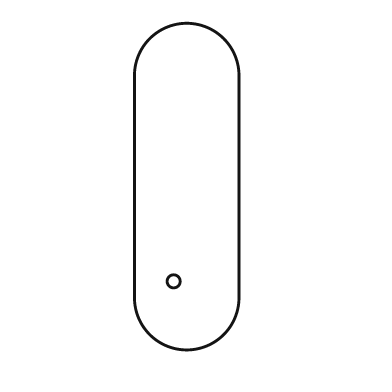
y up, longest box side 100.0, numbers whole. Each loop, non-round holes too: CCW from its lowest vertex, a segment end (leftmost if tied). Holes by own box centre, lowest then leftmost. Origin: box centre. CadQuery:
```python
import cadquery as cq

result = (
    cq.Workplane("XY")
    .moveTo(-16.0, -34.0)
    .threePointArc((0.0, -50.0), (16.0, -34.0))
    .lineTo(16.0, 34.0)
    .threePointArc((0.0, 50.0), (-16.0, 34.0))
    .close()
    .moveTo(-4.0, -29.0)
    .circle(2.0)
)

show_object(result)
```